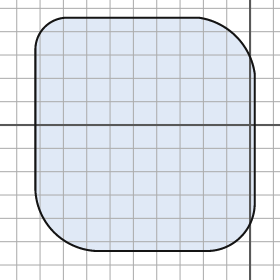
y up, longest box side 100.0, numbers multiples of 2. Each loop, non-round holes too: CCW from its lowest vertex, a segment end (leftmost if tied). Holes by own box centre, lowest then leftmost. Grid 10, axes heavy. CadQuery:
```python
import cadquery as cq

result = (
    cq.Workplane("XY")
    .moveTo(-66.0, -54.0)
    .lineTo(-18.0, -54.0)
    .threePointArc((-4.0, -48.0), (2.0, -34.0))
    .lineTo(2.0, 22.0)
    .threePointArc((-6.0, 38.0), (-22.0, 46.0))
    .lineTo(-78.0, 46.0)
    .threePointArc((-88.0, 42.0), (-92.0, 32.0))
    .lineTo(-92.0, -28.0)
    .threePointArc((-84.0, -46.0), (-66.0, -54.0))
    .close()
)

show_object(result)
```